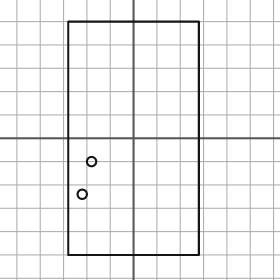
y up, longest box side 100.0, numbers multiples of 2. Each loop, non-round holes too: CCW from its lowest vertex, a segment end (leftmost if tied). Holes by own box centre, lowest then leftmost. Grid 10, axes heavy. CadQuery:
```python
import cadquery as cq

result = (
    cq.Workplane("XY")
    .moveTo(-28.0, -50.0)
    .lineTo(28.0, -50.0)
    .lineTo(28.0, 50.0)
    .lineTo(-28.0, 50.0)
    .close()
    .moveTo(-22.0, -24.0)
    .circle(2.0)
    .moveTo(-18.0, -10.0)
    .circle(2.0)
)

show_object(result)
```